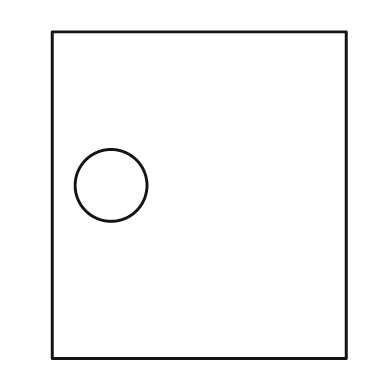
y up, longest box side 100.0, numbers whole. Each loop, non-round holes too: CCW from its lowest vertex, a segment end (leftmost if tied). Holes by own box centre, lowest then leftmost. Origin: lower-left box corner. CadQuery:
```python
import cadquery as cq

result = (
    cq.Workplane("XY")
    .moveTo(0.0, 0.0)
    .lineTo(90.0, 0.0)
    .lineTo(90.0, 100.0)
    .lineTo(0.0, 100.0)
    .close()
    .moveTo(18.0, 53.0)
    .circle(11.0)
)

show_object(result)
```